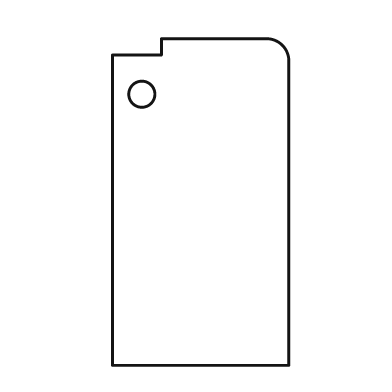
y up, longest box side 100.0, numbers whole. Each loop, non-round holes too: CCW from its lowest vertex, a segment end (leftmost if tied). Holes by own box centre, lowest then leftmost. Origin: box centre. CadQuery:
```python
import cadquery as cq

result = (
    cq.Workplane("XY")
    .moveTo(-27.0, -50.0)
    .lineTo(27.0, -50.0)
    .lineTo(27.0, 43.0)
    .threePointArc((25.0, 48.0), (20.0, 50.0))
    .lineTo(-12.0, 50.0)
    .lineTo(-12.0, 45.0)
    .lineTo(-27.0, 45.0)
    .close()
    .moveTo(-18.0, 33.0)
    .circle(4.0)
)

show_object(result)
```